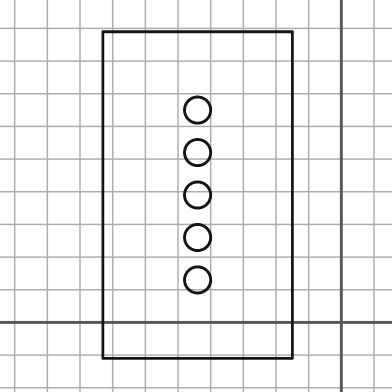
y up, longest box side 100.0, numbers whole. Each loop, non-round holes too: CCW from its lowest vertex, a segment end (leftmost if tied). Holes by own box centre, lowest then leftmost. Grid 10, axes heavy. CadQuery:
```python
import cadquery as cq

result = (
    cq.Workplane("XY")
    .moveTo(-73.0, -11.0)
    .lineTo(-15.0, -11.0)
    .lineTo(-15.0, 89.0)
    .lineTo(-73.0, 89.0)
    .close()
    .moveTo(-44.0, 13.0)
    .circle(4.0)
    .moveTo(-44.0, 26.0)
    .circle(4.0)
    .moveTo(-44.0, 39.0)
    .circle(4.0)
    .moveTo(-44.0, 52.0)
    .circle(4.0)
    .moveTo(-44.0, 65.0)
    .circle(4.0)
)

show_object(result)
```